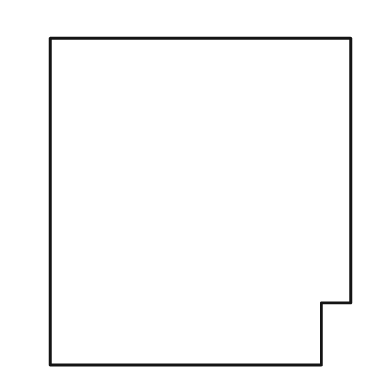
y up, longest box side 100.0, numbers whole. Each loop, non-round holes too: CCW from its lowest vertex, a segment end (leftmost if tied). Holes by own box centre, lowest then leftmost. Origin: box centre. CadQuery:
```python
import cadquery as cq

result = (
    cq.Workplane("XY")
    .moveTo(-46.0, -50.0)
    .lineTo(37.0, -50.0)
    .lineTo(37.0, -31.0)
    .lineTo(46.0, -31.0)
    .lineTo(46.0, 50.0)
    .lineTo(-46.0, 50.0)
    .close()
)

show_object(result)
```